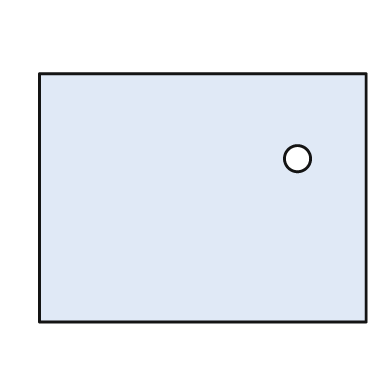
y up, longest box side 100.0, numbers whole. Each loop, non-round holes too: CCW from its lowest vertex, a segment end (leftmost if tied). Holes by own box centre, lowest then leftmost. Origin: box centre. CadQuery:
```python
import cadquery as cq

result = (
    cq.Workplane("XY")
    .moveTo(-50.0, -38.0)
    .lineTo(50.0, -38.0)
    .lineTo(50.0, 38.0)
    .lineTo(-50.0, 38.0)
    .close()
    .moveTo(29.0, 12.0)
    .circle(4.0)
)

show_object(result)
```